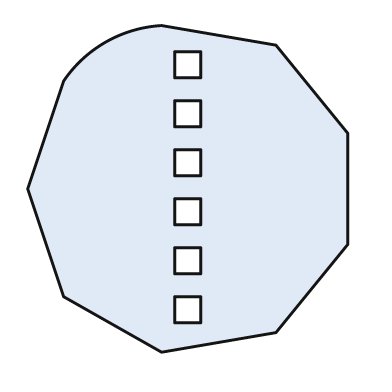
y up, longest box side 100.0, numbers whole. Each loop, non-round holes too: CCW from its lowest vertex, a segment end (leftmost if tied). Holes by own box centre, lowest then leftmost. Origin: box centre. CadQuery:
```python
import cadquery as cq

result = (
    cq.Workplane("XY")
    .moveTo(-8.0, -50.0)
    .lineTo(27.0, -44.0)
    .lineTo(49.0, -17.0)
    .lineTo(49.0, 17.0)
    .lineTo(27.0, 44.0)
    .lineTo(-8.0, 50.0)
    .threePointArc((-25.0, 45.0), (-38.0, 33.0))
    .lineTo(-49.0, 0.0)
    .lineTo(-38.0, -33.0)
    .close()
    .moveTo(-4.0, -41.0)
    .lineTo(4.0, -41.0)
    .lineTo(4.0, -33.0)
    .lineTo(-4.0, -33.0)
    .close()
    .moveTo(-4.0, -26.0)
    .lineTo(4.0, -26.0)
    .lineTo(4.0, -18.0)
    .lineTo(-4.0, -18.0)
    .close()
    .moveTo(-4.0, -11.0)
    .lineTo(4.0, -11.0)
    .lineTo(4.0, -3.0)
    .lineTo(-4.0, -3.0)
    .close()
    .moveTo(-4.0, 4.0)
    .lineTo(4.0, 4.0)
    .lineTo(4.0, 12.0)
    .lineTo(-4.0, 12.0)
    .close()
    .moveTo(-4.0, 19.0)
    .lineTo(4.0, 19.0)
    .lineTo(4.0, 27.0)
    .lineTo(-4.0, 27.0)
    .close()
    .moveTo(-4.0, 34.0)
    .lineTo(4.0, 34.0)
    .lineTo(4.0, 42.0)
    .lineTo(-4.0, 42.0)
    .close()
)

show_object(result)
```